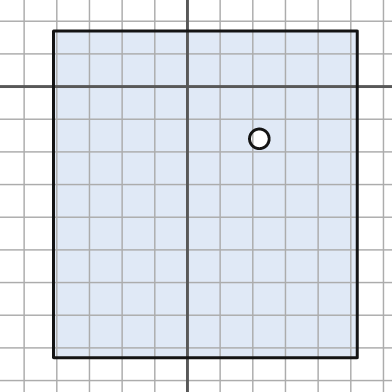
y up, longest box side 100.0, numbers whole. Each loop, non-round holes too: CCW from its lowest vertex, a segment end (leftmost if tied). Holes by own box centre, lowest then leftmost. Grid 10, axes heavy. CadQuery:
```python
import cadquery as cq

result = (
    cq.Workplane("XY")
    .moveTo(-41.0, -83.0)
    .lineTo(52.0, -83.0)
    .lineTo(52.0, 17.0)
    .lineTo(-41.0, 17.0)
    .close()
    .moveTo(22.0, -16.0)
    .circle(3.0)
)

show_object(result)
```